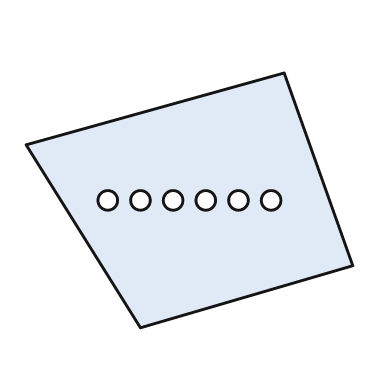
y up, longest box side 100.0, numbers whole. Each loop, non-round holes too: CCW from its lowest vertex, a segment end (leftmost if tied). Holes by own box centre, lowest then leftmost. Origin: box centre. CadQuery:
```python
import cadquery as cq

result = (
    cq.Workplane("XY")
    .moveTo(-15.0, -39.0)
    .lineTo(50.0, -20.0)
    .lineTo(29.0, 39.0)
    .lineTo(-50.0, 17.0)
    .close()
    .moveTo(-25.0, 0.0)
    .circle(3.0)
    .moveTo(-15.0, 0.0)
    .circle(3.0)
    .moveTo(-5.0, 0.0)
    .circle(3.0)
    .moveTo(5.0, 0.0)
    .circle(3.0)
    .moveTo(15.0, 0.0)
    .circle(3.0)
    .moveTo(25.0, 0.0)
    .circle(3.0)
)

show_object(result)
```